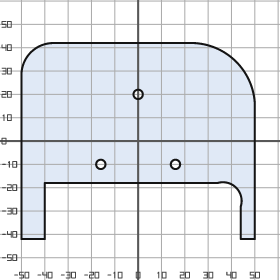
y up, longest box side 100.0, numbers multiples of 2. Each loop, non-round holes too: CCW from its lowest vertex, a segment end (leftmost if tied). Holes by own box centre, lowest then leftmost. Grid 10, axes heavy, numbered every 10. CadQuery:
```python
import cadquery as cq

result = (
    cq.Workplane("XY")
    .moveTo(-50.0, -42.0)
    .lineTo(-40.0, -42.0)
    .lineTo(-40.0, -18.0)
    .lineTo(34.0, -18.0)
    .threePointArc((42.0, -20.0), (44.0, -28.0))
    .lineTo(44.0, -42.0)
    .lineTo(50.0, -42.0)
    .lineTo(50.0, 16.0)
    .threePointArc((42.0, 34.0), (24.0, 42.0))
    .lineTo(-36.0, 42.0)
    .threePointArc((-46.0, 38.0), (-50.0, 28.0))
    .close()
    .moveTo(-16.0, -10.0)
    .circle(2.0)
    .moveTo(16.0, -10.0)
    .circle(2.0)
    .moveTo(0.0, 20.0)
    .circle(2.0)
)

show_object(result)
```